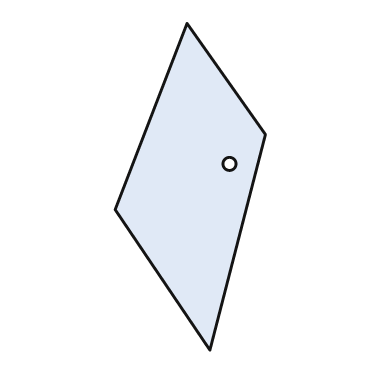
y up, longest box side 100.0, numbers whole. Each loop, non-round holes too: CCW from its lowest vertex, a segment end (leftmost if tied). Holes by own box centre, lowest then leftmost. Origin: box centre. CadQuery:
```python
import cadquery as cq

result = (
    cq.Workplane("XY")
    .moveTo(6.0, -50.0)
    .lineTo(23.0, 16.0)
    .lineTo(-1.0, 50.0)
    .lineTo(-23.0, -7.0)
    .close()
    .moveTo(12.0, 7.0)
    .circle(2.0)
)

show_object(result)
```